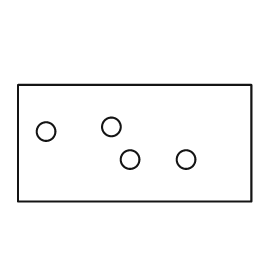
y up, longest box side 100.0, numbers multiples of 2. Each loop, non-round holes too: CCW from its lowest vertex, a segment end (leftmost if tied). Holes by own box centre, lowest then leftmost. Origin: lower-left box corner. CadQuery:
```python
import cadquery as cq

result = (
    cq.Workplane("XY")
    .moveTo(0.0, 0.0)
    .lineTo(100.0, 0.0)
    .lineTo(100.0, 50.0)
    .lineTo(0.0, 50.0)
    .close()
    .moveTo(48.0, 18.0)
    .circle(4.0)
    .moveTo(72.0, 18.0)
    .circle(4.0)
    .moveTo(12.0, 30.0)
    .circle(4.0)
    .moveTo(40.0, 32.0)
    .circle(4.0)
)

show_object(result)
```